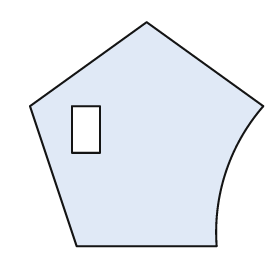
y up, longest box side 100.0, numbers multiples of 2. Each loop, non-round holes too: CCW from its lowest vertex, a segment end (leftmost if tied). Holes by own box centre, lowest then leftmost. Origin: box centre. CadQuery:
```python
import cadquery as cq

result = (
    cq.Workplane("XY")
    .moveTo(-30.0, -48.0)
    .lineTo(30.0, -48.0)
    .threePointArc((34.0, -16.0), (50.0, 12.0))
    .lineTo(0.0, 48.0)
    .lineTo(-50.0, 12.0)
    .close()
    .moveTo(-32.0, -8.0)
    .lineTo(-20.0, -8.0)
    .lineTo(-20.0, 12.0)
    .lineTo(-32.0, 12.0)
    .close()
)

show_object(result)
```